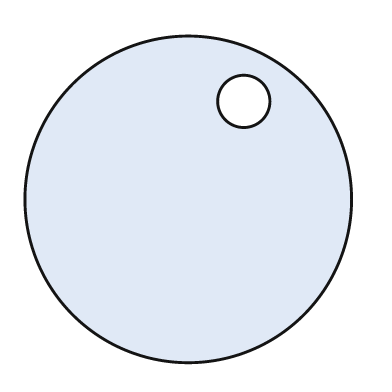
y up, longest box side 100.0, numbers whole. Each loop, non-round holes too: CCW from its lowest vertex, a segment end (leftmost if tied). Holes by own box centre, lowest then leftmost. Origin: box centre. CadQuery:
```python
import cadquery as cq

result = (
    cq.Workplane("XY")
    .moveTo(0.0, 0.0)
    .circle(50.0)
    .moveTo(17.0, 30.0)
    .circle(8.0)
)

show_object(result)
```